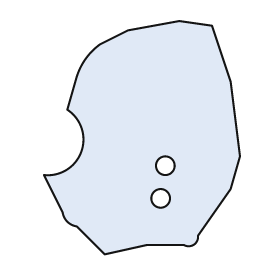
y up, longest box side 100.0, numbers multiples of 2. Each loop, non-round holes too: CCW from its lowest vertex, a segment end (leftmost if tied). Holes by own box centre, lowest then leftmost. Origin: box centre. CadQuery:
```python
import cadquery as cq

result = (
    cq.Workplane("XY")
    .moveTo(-16.0, -50.0)
    .lineTo(2.0, -46.0)
    .lineTo(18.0, -46.0)
    .threePointArc((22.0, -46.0), (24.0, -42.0))
    .lineTo(38.0, -22.0)
    .lineTo(42.0, -8.0)
    .lineTo(38.0, 24.0)
    .lineTo(30.0, 48.0)
    .lineTo(16.0, 50.0)
    .lineTo(-6.0, 46.0)
    .lineTo(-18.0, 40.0)
    .threePointArc((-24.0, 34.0), (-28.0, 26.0))
    .lineTo(-32.0, 12.0)
    .threePointArc((-26.0, -6.0), (-42.0, -16.0))
    .lineTo(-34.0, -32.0)
    .threePointArc((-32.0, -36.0), (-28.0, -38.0))
    .close()
    .moveTo(8.0, -26.0)
    .circle(4.0)
    .moveTo(10.0, -12.0)
    .circle(4.0)
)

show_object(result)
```